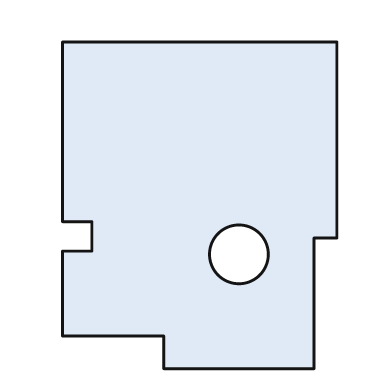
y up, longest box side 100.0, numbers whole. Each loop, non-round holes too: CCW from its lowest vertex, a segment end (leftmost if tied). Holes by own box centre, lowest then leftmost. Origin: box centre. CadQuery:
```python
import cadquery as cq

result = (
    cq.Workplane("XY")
    .moveTo(-11.0, -50.0)
    .lineTo(35.0, -50.0)
    .lineTo(35.0, -10.0)
    .lineTo(42.0, -10.0)
    .lineTo(42.0, 50.0)
    .lineTo(-42.0, 50.0)
    .lineTo(-42.0, -5.0)
    .lineTo(-33.0, -5.0)
    .lineTo(-33.0, -14.0)
    .lineTo(-42.0, -14.0)
    .lineTo(-42.0, -40.0)
    .lineTo(-11.0, -40.0)
    .close()
    .moveTo(12.0, -15.0)
    .circle(9.0)
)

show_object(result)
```